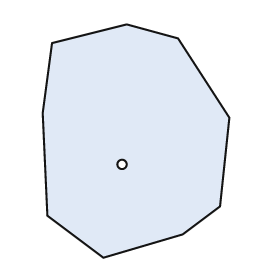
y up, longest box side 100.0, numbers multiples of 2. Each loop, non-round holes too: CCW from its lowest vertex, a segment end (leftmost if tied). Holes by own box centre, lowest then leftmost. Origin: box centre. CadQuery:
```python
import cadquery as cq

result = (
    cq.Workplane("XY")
    .moveTo(-14.0, -50.0)
    .lineTo(20.0, -40.0)
    .lineTo(36.0, -28.0)
    .lineTo(40.0, 10.0)
    .lineTo(18.0, 44.0)
    .lineTo(-4.0, 50.0)
    .lineTo(-36.0, 42.0)
    .lineTo(-40.0, 12.0)
    .lineTo(-38.0, -32.0)
    .close()
    .moveTo(-6.0, -10.0)
    .circle(2.0)
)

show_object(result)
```